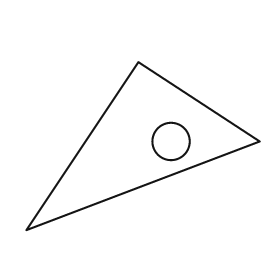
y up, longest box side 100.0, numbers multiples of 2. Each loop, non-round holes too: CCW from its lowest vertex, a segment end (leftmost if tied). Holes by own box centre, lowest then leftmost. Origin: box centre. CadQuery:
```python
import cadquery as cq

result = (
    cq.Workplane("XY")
    .moveTo(-50.0, -36.0)
    .lineTo(50.0, 2.0)
    .lineTo(-2.0, 36.0)
    .close()
    .moveTo(12.0, 2.0)
    .circle(8.0)
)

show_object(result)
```